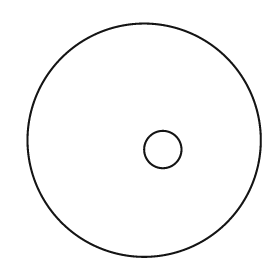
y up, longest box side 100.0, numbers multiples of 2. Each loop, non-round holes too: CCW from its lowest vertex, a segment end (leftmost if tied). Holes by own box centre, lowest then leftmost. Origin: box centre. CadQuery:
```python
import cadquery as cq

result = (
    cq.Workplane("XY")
    .moveTo(0.0, 0.0)
    .circle(50.0)
    .moveTo(8.0, -4.0)
    .circle(8.0)
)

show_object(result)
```